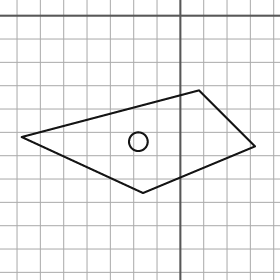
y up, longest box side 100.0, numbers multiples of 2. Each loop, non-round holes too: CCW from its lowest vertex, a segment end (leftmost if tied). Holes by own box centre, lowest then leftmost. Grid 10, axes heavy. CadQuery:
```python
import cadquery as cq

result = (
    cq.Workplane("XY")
    .moveTo(-16.0, -76.0)
    .lineTo(32.0, -56.0)
    .lineTo(8.0, -32.0)
    .lineTo(-68.0, -52.0)
    .close()
    .moveTo(-18.0, -54.0)
    .circle(4.0)
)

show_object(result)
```